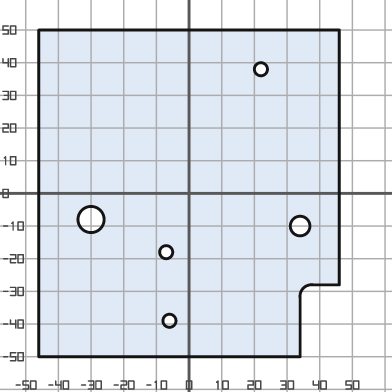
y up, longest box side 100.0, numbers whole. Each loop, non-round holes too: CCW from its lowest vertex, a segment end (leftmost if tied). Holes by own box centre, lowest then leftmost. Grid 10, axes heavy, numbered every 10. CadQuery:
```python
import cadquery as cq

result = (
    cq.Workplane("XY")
    .moveTo(-46.0, -50.0)
    .lineTo(34.0, -50.0)
    .lineTo(34.0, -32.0)
    .threePointArc((35.0, -29.0), (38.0, -28.0))
    .lineTo(46.0, -28.0)
    .lineTo(46.0, 50.0)
    .lineTo(-46.0, 50.0)
    .close()
    .moveTo(-6.0, -39.0)
    .circle(2.0)
    .moveTo(-7.0, -18.0)
    .circle(2.0)
    .moveTo(34.0, -10.0)
    .circle(3.0)
    .moveTo(-30.0, -8.0)
    .circle(4.0)
    .moveTo(22.0, 38.0)
    .circle(2.0)
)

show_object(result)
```